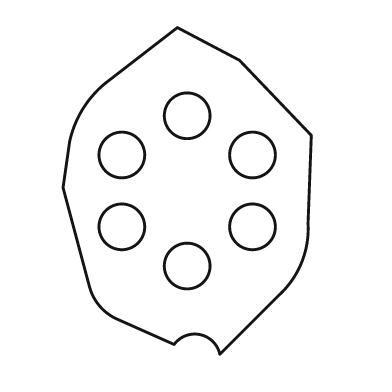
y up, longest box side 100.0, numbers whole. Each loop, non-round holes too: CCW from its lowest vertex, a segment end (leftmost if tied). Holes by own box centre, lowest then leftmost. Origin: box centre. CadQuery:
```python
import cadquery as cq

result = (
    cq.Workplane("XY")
    .moveTo(10.0, -50.0)
    .lineTo(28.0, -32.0)
    .threePointArc((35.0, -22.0), (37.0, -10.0))
    .lineTo(38.0, 17.0)
    .lineTo(16.0, 40.0)
    .lineTo(-3.0, 50.0)
    .lineTo(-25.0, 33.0)
    .threePointArc((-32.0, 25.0), (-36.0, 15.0))
    .lineTo(-38.0, 1.0)
    .lineTo(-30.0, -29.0)
    .threePointArc((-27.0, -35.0), (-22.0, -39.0))
    .lineTo(-4.0, -47.0)
    .threePointArc((4.0, -44.0), (10.0, -50.0))
    .close()
    .moveTo(0.0, -23.0)
    .circle(7.0)
    .moveTo(-20.0, -11.0)
    .circle(7.0)
    .moveTo(20.0, -11.0)
    .circle(7.0)
    .moveTo(-20.0, 11.0)
    .circle(7.0)
    .moveTo(20.0, 11.0)
    .circle(7.0)
    .moveTo(0.0, 23.0)
    .circle(7.0)
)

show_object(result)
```